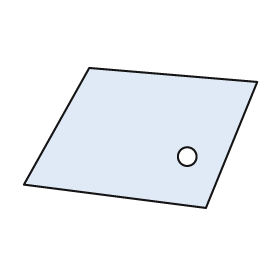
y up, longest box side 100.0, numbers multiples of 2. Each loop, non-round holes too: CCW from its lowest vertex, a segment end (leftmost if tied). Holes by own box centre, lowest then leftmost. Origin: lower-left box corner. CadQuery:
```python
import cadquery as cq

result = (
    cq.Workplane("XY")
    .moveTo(78.0, 0.0)
    .lineTo(100.0, 54.0)
    .lineTo(28.0, 60.0)
    .lineTo(0.0, 10.0)
    .close()
    .moveTo(70.0, 22.0)
    .circle(4.0)
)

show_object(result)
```